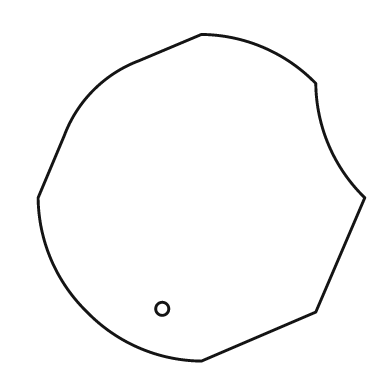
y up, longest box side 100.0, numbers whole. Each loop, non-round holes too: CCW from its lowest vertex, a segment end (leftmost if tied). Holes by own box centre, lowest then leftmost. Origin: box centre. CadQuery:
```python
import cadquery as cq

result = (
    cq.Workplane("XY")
    .moveTo(0.0, -50.0)
    .lineTo(35.0, -35.0)
    .lineTo(50.0, 0.0)
    .threePointArc((39.0, 16.0), (35.0, 35.0))
    .threePointArc((19.0, 46.0), (0.0, 50.0))
    .lineTo(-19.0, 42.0)
    .threePointArc((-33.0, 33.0), (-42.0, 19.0))
    .lineTo(-50.0, 0.0)
    .threePointArc((-46.0, -19.0), (-35.0, -35.0))
    .threePointArc((-19.0, -46.0), (0.0, -50.0))
    .close()
    .moveTo(-12.0, -34.0)
    .circle(2.0)
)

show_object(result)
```